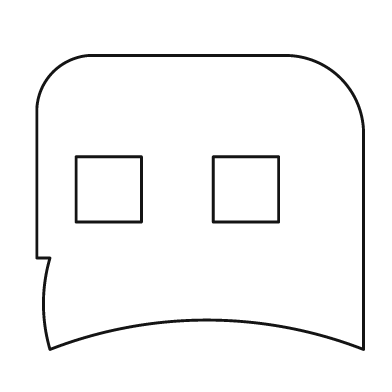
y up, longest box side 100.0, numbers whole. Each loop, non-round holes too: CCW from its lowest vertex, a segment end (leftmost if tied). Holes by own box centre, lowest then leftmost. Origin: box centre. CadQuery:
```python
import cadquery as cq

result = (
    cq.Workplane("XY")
    .moveTo(-46.0, -45.0)
    .threePointArc((2.0, -36.0), (50.0, -45.0))
    .lineTo(50.0, 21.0)
    .threePointArc((43.0, 38.0), (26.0, 45.0))
    .lineTo(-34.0, 45.0)
    .threePointArc((-45.0, 40.0), (-50.0, 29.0))
    .lineTo(-50.0, -17.0)
    .lineTo(-46.0, -17.0)
    .threePointArc((-48.0, -31.0), (-46.0, -45.0))
    .close()
    .moveTo(-38.0, -6.0)
    .lineTo(-18.0, -6.0)
    .lineTo(-18.0, 14.0)
    .lineTo(-38.0, 14.0)
    .close()
    .moveTo(4.0, -6.0)
    .lineTo(24.0, -6.0)
    .lineTo(24.0, 14.0)
    .lineTo(4.0, 14.0)
    .close()
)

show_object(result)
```